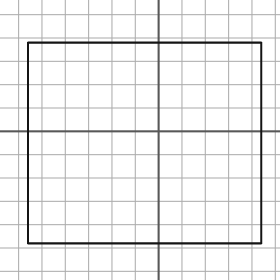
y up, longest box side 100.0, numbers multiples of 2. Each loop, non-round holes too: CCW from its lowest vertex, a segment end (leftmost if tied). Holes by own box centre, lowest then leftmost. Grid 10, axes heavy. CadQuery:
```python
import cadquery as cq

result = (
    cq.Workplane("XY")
    .moveTo(-56.0, -48.0)
    .lineTo(44.0, -48.0)
    .lineTo(44.0, 38.0)
    .lineTo(-56.0, 38.0)
    .close()
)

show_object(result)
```